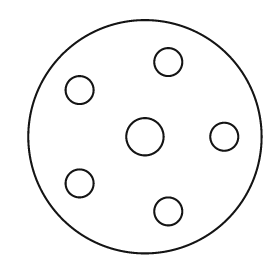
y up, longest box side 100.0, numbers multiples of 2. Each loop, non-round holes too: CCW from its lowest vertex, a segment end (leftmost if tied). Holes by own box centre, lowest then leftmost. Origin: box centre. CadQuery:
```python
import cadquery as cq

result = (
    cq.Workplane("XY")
    .moveTo(0.0, 0.0)
    .circle(50.0)
    .moveTo(10.0, -32.0)
    .circle(6.0)
    .moveTo(-28.0, -20.0)
    .circle(6.0)
    .moveTo(0.0, 0.0)
    .circle(8.0)
    .moveTo(34.0, 0.0)
    .circle(6.0)
    .moveTo(-28.0, 20.0)
    .circle(6.0)
    .moveTo(10.0, 32.0)
    .circle(6.0)
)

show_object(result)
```